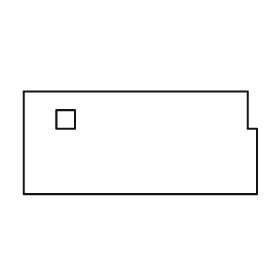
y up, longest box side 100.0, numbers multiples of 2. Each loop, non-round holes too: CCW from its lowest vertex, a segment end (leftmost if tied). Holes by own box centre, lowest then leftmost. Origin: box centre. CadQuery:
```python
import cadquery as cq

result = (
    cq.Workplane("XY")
    .moveTo(-50.0, -22.0)
    .lineTo(50.0, -22.0)
    .lineTo(50.0, 6.0)
    .lineTo(46.0, 6.0)
    .lineTo(46.0, 22.0)
    .lineTo(-50.0, 22.0)
    .close()
    .moveTo(-36.0, 6.0)
    .lineTo(-28.0, 6.0)
    .lineTo(-28.0, 14.0)
    .lineTo(-36.0, 14.0)
    .close()
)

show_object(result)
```